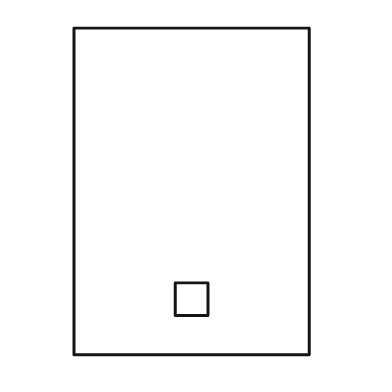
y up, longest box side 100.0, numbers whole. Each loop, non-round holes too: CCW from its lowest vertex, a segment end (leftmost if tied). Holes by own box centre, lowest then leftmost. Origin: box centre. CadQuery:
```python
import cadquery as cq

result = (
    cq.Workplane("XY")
    .moveTo(-36.0, -50.0)
    .lineTo(36.0, -50.0)
    .lineTo(36.0, 50.0)
    .lineTo(-36.0, 50.0)
    .close()
    .moveTo(-5.0, -38.0)
    .lineTo(5.0, -38.0)
    .lineTo(5.0, -28.0)
    .lineTo(-5.0, -28.0)
    .close()
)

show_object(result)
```